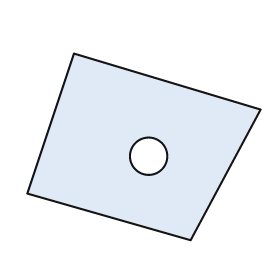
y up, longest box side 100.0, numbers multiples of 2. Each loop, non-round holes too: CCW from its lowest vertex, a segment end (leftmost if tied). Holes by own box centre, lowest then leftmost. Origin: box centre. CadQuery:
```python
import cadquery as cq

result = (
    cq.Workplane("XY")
    .moveTo(20.0, -40.0)
    .lineTo(50.0, 16.0)
    .lineTo(-30.0, 40.0)
    .lineTo(-50.0, -20.0)
    .close()
    .moveTo(2.0, -4.0)
    .circle(8.0)
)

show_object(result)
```